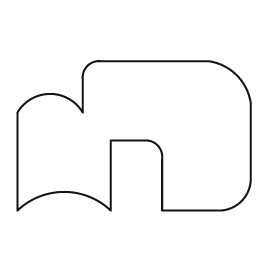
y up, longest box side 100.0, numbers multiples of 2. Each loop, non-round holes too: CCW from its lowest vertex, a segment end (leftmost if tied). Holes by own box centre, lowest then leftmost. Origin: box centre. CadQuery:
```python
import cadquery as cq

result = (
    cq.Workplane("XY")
    .moveTo(-50.0, -32.0)
    .threePointArc((-30.0, -24.0), (-10.0, -32.0))
    .lineTo(-10.0, -2.0)
    .lineTo(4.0, -2.0)
    .threePointArc((10.0, -4.0), (12.0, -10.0))
    .lineTo(12.0, -32.0)
    .lineTo(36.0, -32.0)
    .threePointArc((46.0, -28.0), (50.0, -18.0))
    .lineTo(50.0, 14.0)
    .threePointArc((44.0, 26.0), (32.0, 32.0))
    .lineTo(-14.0, 32.0)
    .threePointArc((-20.0, 30.0), (-22.0, 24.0))
    .lineTo(-22.0, 10.0)
    .threePointArc((-36.0, 18.0), (-50.0, 10.0))
    .close()
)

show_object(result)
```